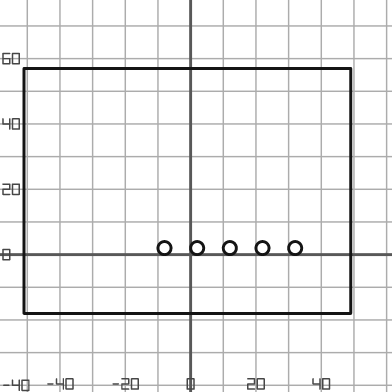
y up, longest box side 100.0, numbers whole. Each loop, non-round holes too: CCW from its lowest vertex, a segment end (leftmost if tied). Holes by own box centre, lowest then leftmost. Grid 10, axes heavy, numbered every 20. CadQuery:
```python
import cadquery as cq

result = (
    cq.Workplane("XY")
    .moveTo(-51.0, -18.0)
    .lineTo(49.0, -18.0)
    .lineTo(49.0, 57.0)
    .lineTo(-51.0, 57.0)
    .close()
    .moveTo(-8.0, 2.0)
    .circle(2.0)
    .moveTo(2.0, 2.0)
    .circle(2.0)
    .moveTo(12.0, 2.0)
    .circle(2.0)
    .moveTo(22.0, 2.0)
    .circle(2.0)
    .moveTo(32.0, 2.0)
    .circle(2.0)
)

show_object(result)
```